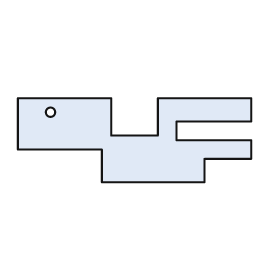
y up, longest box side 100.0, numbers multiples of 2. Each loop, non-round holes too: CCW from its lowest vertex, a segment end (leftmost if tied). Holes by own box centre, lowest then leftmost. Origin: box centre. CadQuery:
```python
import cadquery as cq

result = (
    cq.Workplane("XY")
    .moveTo(-14.0, -18.0)
    .lineTo(30.0, -18.0)
    .lineTo(30.0, -8.0)
    .lineTo(50.0, -8.0)
    .lineTo(50.0, 0.0)
    .lineTo(18.0, 0.0)
    .lineTo(18.0, 8.0)
    .lineTo(50.0, 8.0)
    .lineTo(50.0, 18.0)
    .lineTo(10.0, 18.0)
    .lineTo(10.0, 2.0)
    .lineTo(-10.0, 2.0)
    .lineTo(-10.0, 18.0)
    .lineTo(-50.0, 18.0)
    .lineTo(-50.0, -4.0)
    .lineTo(-14.0, -4.0)
    .close()
    .moveTo(-36.0, 12.0)
    .circle(2.0)
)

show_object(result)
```